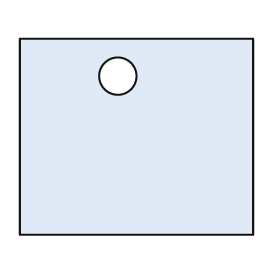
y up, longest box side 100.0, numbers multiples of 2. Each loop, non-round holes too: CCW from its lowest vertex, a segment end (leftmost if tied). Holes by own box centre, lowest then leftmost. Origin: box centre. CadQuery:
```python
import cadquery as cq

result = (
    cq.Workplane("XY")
    .moveTo(-50.0, -42.0)
    .lineTo(50.0, -42.0)
    .lineTo(50.0, 42.0)
    .lineTo(-50.0, 42.0)
    .close()
    .moveTo(-8.0, 26.0)
    .circle(8.0)
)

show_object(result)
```